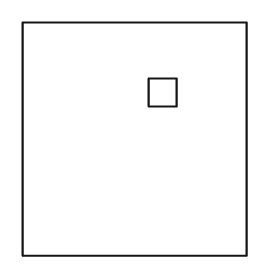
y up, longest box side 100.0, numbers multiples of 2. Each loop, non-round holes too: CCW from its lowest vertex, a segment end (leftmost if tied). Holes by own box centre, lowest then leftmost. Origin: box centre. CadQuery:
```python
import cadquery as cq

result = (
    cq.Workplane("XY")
    .moveTo(-48.0, -50.0)
    .lineTo(48.0, -50.0)
    .lineTo(48.0, 50.0)
    .lineTo(-48.0, 50.0)
    .close()
    .moveTo(6.0, 14.0)
    .lineTo(18.0, 14.0)
    .lineTo(18.0, 26.0)
    .lineTo(6.0, 26.0)
    .close()
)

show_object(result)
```